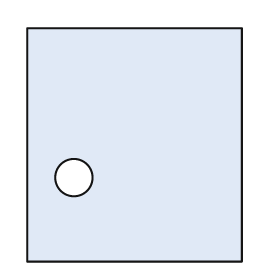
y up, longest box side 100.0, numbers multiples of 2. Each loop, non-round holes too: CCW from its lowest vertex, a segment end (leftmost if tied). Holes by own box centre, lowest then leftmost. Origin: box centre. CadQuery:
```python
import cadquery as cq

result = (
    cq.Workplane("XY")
    .moveTo(-46.0, -50.0)
    .lineTo(46.0, -50.0)
    .lineTo(46.0, 50.0)
    .lineTo(-46.0, 50.0)
    .close()
    .moveTo(-26.0, -14.0)
    .circle(8.0)
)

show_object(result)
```